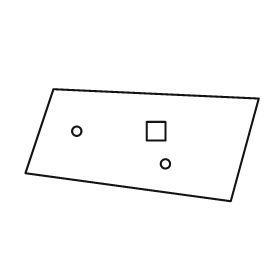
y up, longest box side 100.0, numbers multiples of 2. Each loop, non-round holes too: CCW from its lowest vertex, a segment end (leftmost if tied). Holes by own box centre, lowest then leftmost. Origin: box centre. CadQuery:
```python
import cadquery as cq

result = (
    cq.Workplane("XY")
    .moveTo(38.0, -24.0)
    .lineTo(50.0, 20.0)
    .lineTo(-38.0, 24.0)
    .lineTo(-50.0, -12.0)
    .close()
    .moveTo(10.0, -8.0)
    .circle(2.0)
    .moveTo(-28.0, 6.0)
    .circle(2.0)
    .moveTo(2.0, 2.0)
    .lineTo(10.0, 2.0)
    .lineTo(10.0, 10.0)
    .lineTo(2.0, 10.0)
    .close()
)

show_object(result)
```